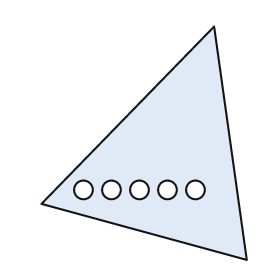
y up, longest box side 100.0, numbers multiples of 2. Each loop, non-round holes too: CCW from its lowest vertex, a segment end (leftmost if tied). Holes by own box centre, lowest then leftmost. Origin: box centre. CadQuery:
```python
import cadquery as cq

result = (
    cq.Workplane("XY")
    .moveTo(44.0, -50.0)
    .lineTo(30.0, 50.0)
    .lineTo(-44.0, -26.0)
    .close()
    .moveTo(-26.0, -20.0)
    .circle(4.0)
    .moveTo(-14.0, -20.0)
    .circle(4.0)
    .moveTo(-2.0, -20.0)
    .circle(4.0)
    .moveTo(10.0, -20.0)
    .circle(4.0)
    .moveTo(22.0, -20.0)
    .circle(4.0)
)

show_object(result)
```